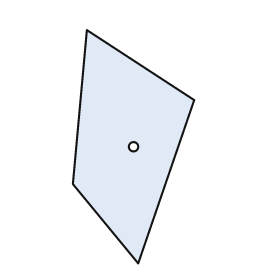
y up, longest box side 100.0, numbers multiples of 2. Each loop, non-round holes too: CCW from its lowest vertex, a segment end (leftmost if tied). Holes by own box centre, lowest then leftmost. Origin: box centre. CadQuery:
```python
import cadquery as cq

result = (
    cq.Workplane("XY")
    .moveTo(2.0, -50.0)
    .lineTo(26.0, 20.0)
    .lineTo(-20.0, 50.0)
    .lineTo(-26.0, -16.0)
    .close()
    .moveTo(0.0, 0.0)
    .circle(2.0)
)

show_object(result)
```